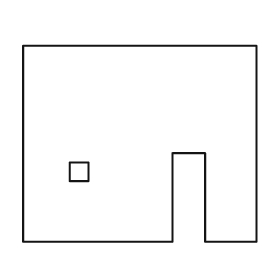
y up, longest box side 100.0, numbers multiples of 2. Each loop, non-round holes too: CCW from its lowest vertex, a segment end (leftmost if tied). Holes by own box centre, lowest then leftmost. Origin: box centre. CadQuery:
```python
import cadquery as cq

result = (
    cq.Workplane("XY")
    .moveTo(-50.0, -42.0)
    .lineTo(14.0, -42.0)
    .lineTo(14.0, -4.0)
    .lineTo(28.0, -4.0)
    .lineTo(28.0, -42.0)
    .lineTo(50.0, -42.0)
    .lineTo(50.0, 42.0)
    .lineTo(-50.0, 42.0)
    .close()
    .moveTo(-30.0, -16.0)
    .lineTo(-22.0, -16.0)
    .lineTo(-22.0, -8.0)
    .lineTo(-30.0, -8.0)
    .close()
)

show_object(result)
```